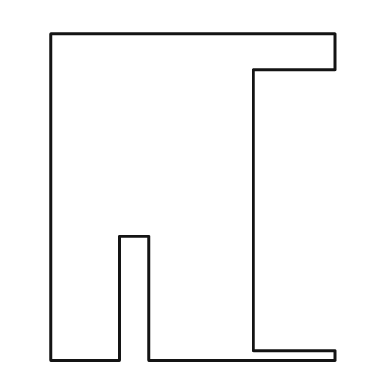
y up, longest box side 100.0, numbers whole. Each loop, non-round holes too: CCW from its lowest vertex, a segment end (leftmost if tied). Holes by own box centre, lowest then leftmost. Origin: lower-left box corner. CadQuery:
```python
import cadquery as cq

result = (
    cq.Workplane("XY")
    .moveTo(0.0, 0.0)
    .lineTo(21.0, 0.0)
    .lineTo(21.0, 38.0)
    .lineTo(30.0, 38.0)
    .lineTo(30.0, 0.0)
    .lineTo(87.0, 0.0)
    .lineTo(87.0, 3.0)
    .lineTo(62.0, 3.0)
    .lineTo(62.0, 89.0)
    .lineTo(87.0, 89.0)
    .lineTo(87.0, 100.0)
    .lineTo(0.0, 100.0)
    .close()
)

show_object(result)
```